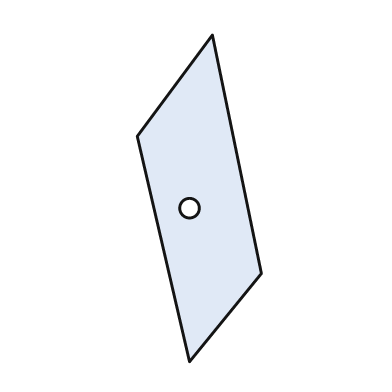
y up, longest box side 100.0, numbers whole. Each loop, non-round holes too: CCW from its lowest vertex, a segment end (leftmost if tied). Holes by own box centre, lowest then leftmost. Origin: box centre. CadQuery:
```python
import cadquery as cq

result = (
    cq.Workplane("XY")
    .moveTo(-3.0, -50.0)
    .lineTo(19.0, -23.0)
    .lineTo(4.0, 50.0)
    .lineTo(-19.0, 19.0)
    .close()
    .moveTo(-3.0, -3.0)
    .circle(3.0)
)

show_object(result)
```